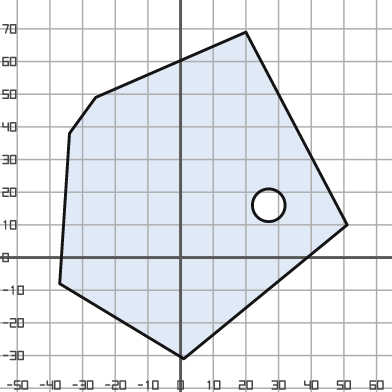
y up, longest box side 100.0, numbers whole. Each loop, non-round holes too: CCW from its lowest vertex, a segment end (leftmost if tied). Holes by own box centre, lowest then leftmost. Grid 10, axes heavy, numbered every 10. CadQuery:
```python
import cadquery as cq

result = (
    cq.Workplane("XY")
    .moveTo(1.0, -31.0)
    .lineTo(51.0, 10.0)
    .lineTo(20.0, 69.0)
    .lineTo(-26.0, 49.0)
    .lineTo(-34.0, 38.0)
    .lineTo(-37.0, -8.0)
    .close()
    .moveTo(27.0, 16.0)
    .circle(5.0)
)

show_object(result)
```